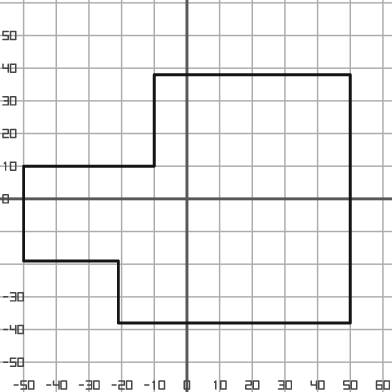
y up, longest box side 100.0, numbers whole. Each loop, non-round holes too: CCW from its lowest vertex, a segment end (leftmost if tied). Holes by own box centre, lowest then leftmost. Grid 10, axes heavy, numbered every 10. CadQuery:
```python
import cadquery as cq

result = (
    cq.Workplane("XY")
    .moveTo(-21.0, -38.0)
    .lineTo(50.0, -38.0)
    .lineTo(50.0, 38.0)
    .lineTo(-10.0, 38.0)
    .lineTo(-10.0, 10.0)
    .lineTo(-50.0, 10.0)
    .lineTo(-50.0, -19.0)
    .lineTo(-21.0, -19.0)
    .close()
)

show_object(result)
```